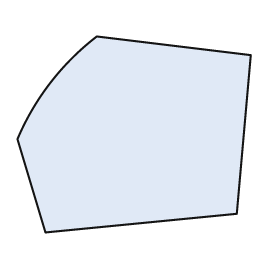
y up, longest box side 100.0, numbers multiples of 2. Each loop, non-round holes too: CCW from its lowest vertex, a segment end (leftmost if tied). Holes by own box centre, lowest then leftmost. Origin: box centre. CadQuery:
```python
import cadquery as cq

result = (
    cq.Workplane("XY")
    .moveTo(-38.0, -42.0)
    .lineTo(44.0, -34.0)
    .lineTo(50.0, 34.0)
    .lineTo(-16.0, 42.0)
    .threePointArc((-36.0, 22.0), (-50.0, -2.0))
    .close()
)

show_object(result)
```